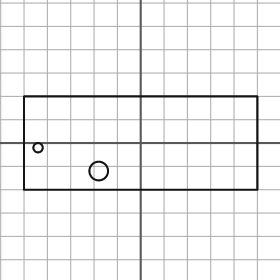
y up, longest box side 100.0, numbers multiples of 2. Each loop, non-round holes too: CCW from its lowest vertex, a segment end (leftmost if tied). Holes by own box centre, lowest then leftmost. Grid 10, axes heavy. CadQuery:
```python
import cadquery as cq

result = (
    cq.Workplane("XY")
    .moveTo(-50.0, -20.0)
    .lineTo(50.0, -20.0)
    .lineTo(50.0, 20.0)
    .lineTo(-50.0, 20.0)
    .close()
    .moveTo(-18.0, -12.0)
    .circle(4.0)
    .moveTo(-44.0, -2.0)
    .circle(2.0)
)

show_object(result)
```